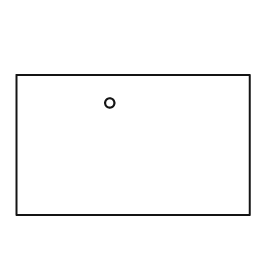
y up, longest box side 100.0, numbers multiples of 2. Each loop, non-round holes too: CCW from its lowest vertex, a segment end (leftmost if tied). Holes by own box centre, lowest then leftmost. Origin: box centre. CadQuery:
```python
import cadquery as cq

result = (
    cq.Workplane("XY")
    .moveTo(-50.0, -30.0)
    .lineTo(50.0, -30.0)
    .lineTo(50.0, 30.0)
    .lineTo(-50.0, 30.0)
    .close()
    .moveTo(-10.0, 18.0)
    .circle(2.0)
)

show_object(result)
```